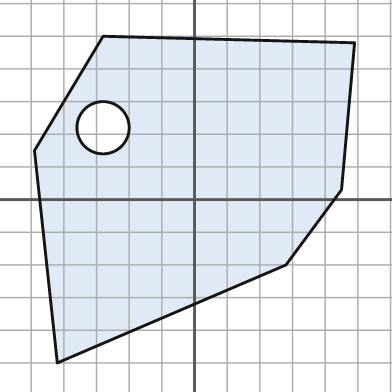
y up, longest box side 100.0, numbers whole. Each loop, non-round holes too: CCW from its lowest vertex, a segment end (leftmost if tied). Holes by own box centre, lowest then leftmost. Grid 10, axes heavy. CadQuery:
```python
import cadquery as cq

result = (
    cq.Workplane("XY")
    .moveTo(-42.0, -50.0)
    .lineTo(28.0, -20.0)
    .lineTo(45.0, 3.0)
    .lineTo(49.0, 48.0)
    .lineTo(-28.0, 50.0)
    .lineTo(-49.0, 15.0)
    .close()
    .moveTo(-28.0, 22.0)
    .circle(8.0)
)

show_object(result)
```